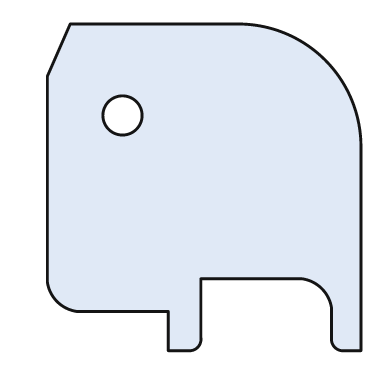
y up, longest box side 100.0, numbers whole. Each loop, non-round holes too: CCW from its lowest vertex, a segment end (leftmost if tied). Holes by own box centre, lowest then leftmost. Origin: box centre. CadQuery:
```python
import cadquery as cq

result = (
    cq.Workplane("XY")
    .moveTo(-11.0, -50.0)
    .lineTo(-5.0, -50.0)
    .threePointArc((-2.0, -49.0), (-1.0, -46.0))
    .lineTo(-1.0, -28.0)
    .lineTo(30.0, -28.0)
    .threePointArc((36.0, -31.0), (39.0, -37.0))
    .lineTo(39.0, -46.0)
    .threePointArc((40.0, -49.0), (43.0, -50.0))
    .lineTo(48.0, -50.0)
    .lineTo(48.0, 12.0)
    .threePointArc((37.0, 39.0), (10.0, 50.0))
    .lineTo(-41.0, 50.0)
    .lineTo(-48.0, 34.0)
    .lineTo(-48.0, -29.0)
    .threePointArc((-45.0, -35.0), (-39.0, -38.0))
    .lineTo(-11.0, -38.0)
    .close()
    .moveTo(-25.0, 22.0)
    .circle(6.0)
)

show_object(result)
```